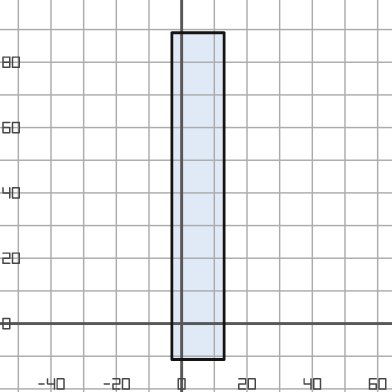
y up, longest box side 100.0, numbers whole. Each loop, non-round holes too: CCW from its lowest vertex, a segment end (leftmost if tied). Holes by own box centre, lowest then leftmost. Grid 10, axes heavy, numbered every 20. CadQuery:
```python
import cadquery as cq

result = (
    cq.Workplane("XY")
    .moveTo(-3.0, -11.0)
    .lineTo(13.0, -11.0)
    .lineTo(13.0, 89.0)
    .lineTo(-3.0, 89.0)
    .close()
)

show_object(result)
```